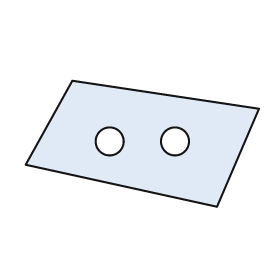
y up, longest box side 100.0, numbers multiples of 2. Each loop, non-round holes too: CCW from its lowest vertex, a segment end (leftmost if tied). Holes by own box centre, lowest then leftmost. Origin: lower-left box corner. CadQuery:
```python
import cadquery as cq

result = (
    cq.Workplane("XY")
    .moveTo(82.0, 0.0)
    .lineTo(100.0, 42.0)
    .lineTo(20.0, 54.0)
    .lineTo(0.0, 18.0)
    .close()
    .moveTo(36.0, 28.0)
    .circle(6.0)
    .moveTo(64.0, 28.0)
    .circle(6.0)
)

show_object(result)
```